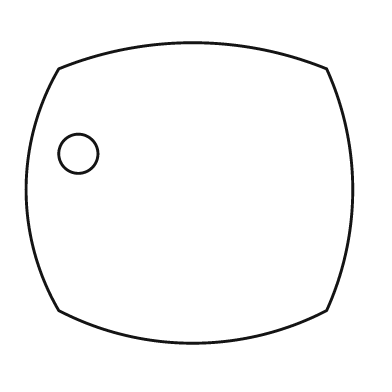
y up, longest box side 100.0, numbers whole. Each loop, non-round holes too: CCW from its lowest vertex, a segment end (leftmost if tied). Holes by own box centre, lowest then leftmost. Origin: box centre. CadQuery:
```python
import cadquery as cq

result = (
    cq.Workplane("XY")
    .moveTo(-40.0, -36.0)
    .threePointArc((1.0, -46.0), (42.0, -36.0))
    .threePointArc((50.0, 1.0), (42.0, 38.0))
    .threePointArc((1.0, 46.0), (-40.0, 38.0))
    .threePointArc((-50.0, 1.0), (-40.0, -36.0))
    .close()
    .moveTo(-34.0, 12.0)
    .circle(6.0)
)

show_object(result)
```